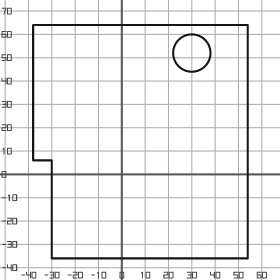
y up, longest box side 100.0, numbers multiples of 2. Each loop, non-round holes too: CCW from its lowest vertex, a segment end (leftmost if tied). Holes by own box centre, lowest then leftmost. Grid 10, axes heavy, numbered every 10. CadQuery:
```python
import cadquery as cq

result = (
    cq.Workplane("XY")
    .moveTo(-30.0, -36.0)
    .lineTo(54.0, -36.0)
    .lineTo(54.0, 64.0)
    .lineTo(-38.0, 64.0)
    .lineTo(-38.0, 6.0)
    .lineTo(-30.0, 6.0)
    .close()
    .moveTo(30.0, 52.0)
    .circle(8.0)
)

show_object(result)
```